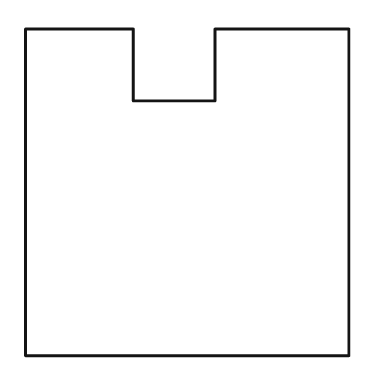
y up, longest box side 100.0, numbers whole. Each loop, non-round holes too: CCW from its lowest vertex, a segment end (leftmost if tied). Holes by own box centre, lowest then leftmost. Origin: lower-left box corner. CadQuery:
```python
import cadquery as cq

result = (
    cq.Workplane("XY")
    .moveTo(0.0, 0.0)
    .lineTo(99.0, 0.0)
    .lineTo(99.0, 100.0)
    .lineTo(58.0, 100.0)
    .lineTo(58.0, 78.0)
    .lineTo(33.0, 78.0)
    .lineTo(33.0, 100.0)
    .lineTo(0.0, 100.0)
    .close()
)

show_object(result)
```